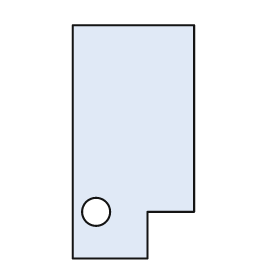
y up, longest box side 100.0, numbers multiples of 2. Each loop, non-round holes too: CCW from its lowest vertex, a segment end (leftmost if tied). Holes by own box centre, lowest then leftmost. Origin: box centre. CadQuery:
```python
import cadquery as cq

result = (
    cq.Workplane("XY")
    .moveTo(-26.0, -50.0)
    .lineTo(6.0, -50.0)
    .lineTo(6.0, -30.0)
    .lineTo(26.0, -30.0)
    .lineTo(26.0, 50.0)
    .lineTo(-26.0, 50.0)
    .close()
    .moveTo(-16.0, -30.0)
    .circle(6.0)
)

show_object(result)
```